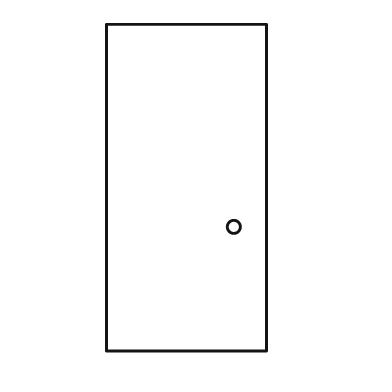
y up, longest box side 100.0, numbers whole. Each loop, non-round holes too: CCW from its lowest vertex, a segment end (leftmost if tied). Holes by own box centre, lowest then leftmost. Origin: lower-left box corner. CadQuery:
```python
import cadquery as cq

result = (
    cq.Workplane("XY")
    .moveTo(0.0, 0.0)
    .lineTo(49.0, 0.0)
    .lineTo(49.0, 100.0)
    .lineTo(0.0, 100.0)
    .close()
    .moveTo(39.0, 38.0)
    .circle(2.0)
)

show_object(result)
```